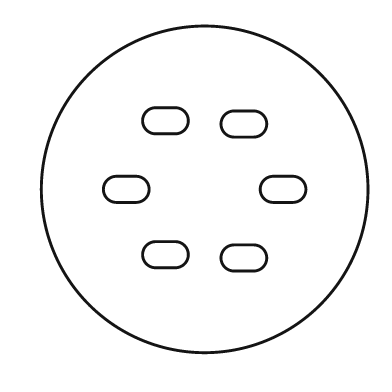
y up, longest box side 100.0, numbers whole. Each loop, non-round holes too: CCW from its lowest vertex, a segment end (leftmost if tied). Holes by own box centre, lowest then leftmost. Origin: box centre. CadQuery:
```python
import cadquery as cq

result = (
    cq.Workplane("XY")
    .moveTo(0.0, 0.0)
    .circle(50.0)
    .moveTo(9.0, -25.0)
    .lineTo(15.0, -25.0)
    .threePointArc((19.0, -21.0), (15.0, -17.0))
    .lineTo(9.0, -17.0)
    .threePointArc((5.0, -21.0), (9.0, -25.0))
    .close()
    .moveTo(-15.0, -24.0)
    .lineTo(-9.0, -24.0)
    .threePointArc((-5.0, -20.0), (-9.0, -16.0))
    .lineTo(-15.0, -16.0)
    .threePointArc((-19.0, -20.0), (-15.0, -24.0))
    .close()
    .moveTo(-27.0, -4.0)
    .lineTo(-21.0, -4.0)
    .threePointArc((-17.0, 0.0), (-21.0, 4.0))
    .lineTo(-27.0, 4.0)
    .threePointArc((-31.0, 0.0), (-27.0, -4.0))
    .close()
    .moveTo(21.0, -4.0)
    .lineTo(27.0, -4.0)
    .threePointArc((31.0, 0.0), (27.0, 4.0))
    .lineTo(21.0, 4.0)
    .threePointArc((17.0, 0.0), (21.0, -4.0))
    .close()
    .moveTo(9.0, 16.0)
    .lineTo(15.0, 16.0)
    .threePointArc((19.0, 20.0), (15.0, 24.0))
    .lineTo(9.0, 24.0)
    .threePointArc((5.0, 20.0), (9.0, 16.0))
    .close()
    .moveTo(-15.0, 17.0)
    .lineTo(-9.0, 17.0)
    .threePointArc((-5.0, 21.0), (-9.0, 25.0))
    .lineTo(-15.0, 25.0)
    .threePointArc((-19.0, 21.0), (-15.0, 17.0))
    .close()
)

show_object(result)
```